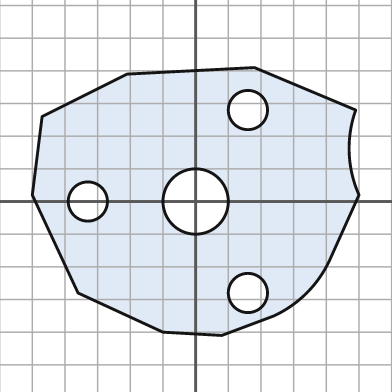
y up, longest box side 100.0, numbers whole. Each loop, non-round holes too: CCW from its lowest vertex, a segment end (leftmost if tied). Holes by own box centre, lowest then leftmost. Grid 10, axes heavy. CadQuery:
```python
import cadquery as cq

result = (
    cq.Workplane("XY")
    .moveTo(8.0, -41.0)
    .lineTo(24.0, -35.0)
    .threePointArc((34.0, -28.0), (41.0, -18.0))
    .lineTo(50.0, 2.0)
    .threePointArc((47.0, 15.0), (49.0, 28.0))
    .lineTo(18.0, 41.0)
    .lineTo(-21.0, 39.0)
    .lineTo(-47.0, 26.0)
    .lineTo(-50.0, 2.0)
    .lineTo(-36.0, -28.0)
    .lineTo(-10.0, -40.0)
    .close()
    .moveTo(16.0, -28.0)
    .circle(6.0)
    .moveTo(-33.0, 0.0)
    .circle(6.0)
    .moveTo(0.0, 0.0)
    .circle(10.0)
    .moveTo(16.0, 28.0)
    .circle(6.0)
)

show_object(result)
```